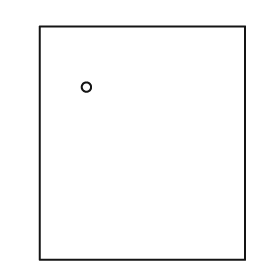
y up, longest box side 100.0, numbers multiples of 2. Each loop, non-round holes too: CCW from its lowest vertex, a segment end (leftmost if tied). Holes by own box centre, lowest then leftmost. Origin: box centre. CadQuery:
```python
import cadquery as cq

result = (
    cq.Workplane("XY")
    .moveTo(-44.0, -50.0)
    .lineTo(44.0, -50.0)
    .lineTo(44.0, 50.0)
    .lineTo(-44.0, 50.0)
    .close()
    .moveTo(-24.0, 24.0)
    .circle(2.0)
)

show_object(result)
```